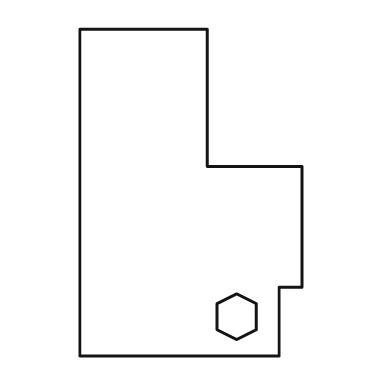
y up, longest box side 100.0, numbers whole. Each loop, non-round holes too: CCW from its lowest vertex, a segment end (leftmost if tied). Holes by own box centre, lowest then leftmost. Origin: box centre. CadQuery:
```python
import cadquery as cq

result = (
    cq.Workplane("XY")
    .moveTo(-34.0, -50.0)
    .lineTo(27.0, -50.0)
    .lineTo(27.0, -29.0)
    .lineTo(34.0, -29.0)
    .lineTo(34.0, 8.0)
    .lineTo(5.0, 8.0)
    .lineTo(5.0, 50.0)
    .lineTo(-34.0, 50.0)
    .close()
    .moveTo(14.0, -45.0)
    .lineTo(20.0, -42.0)
    .lineTo(20.0, -34.0)
    .lineTo(14.0, -31.0)
    .lineTo(8.0, -34.0)
    .lineTo(8.0, -42.0)
    .close()
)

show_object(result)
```